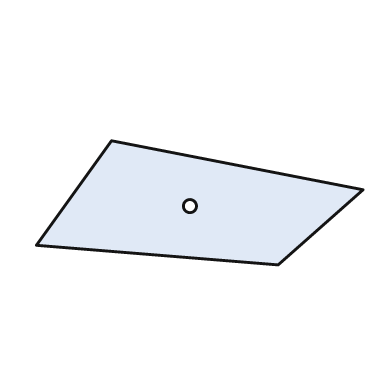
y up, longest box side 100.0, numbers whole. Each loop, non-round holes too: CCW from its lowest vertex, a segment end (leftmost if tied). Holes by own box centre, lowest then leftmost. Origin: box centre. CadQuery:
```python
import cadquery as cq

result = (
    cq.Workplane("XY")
    .moveTo(24.0, -19.0)
    .lineTo(50.0, 4.0)
    .lineTo(-27.0, 19.0)
    .lineTo(-50.0, -13.0)
    .close()
    .moveTo(-3.0, -1.0)
    .circle(2.0)
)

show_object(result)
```